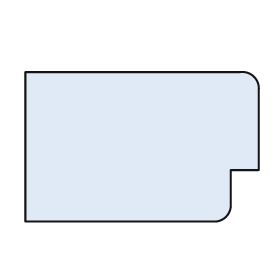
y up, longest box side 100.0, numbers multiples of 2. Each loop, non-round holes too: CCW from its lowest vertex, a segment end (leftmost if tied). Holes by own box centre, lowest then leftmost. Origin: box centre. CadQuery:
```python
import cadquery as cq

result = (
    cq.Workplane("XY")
    .moveTo(-50.0, -32.0)
    .lineTo(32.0, -32.0)
    .threePointArc((36.0, -30.0), (38.0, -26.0))
    .lineTo(38.0, -10.0)
    .lineTo(50.0, -10.0)
    .lineTo(50.0, 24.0)
    .threePointArc((48.0, 30.0), (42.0, 32.0))
    .lineTo(-50.0, 32.0)
    .close()
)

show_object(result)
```